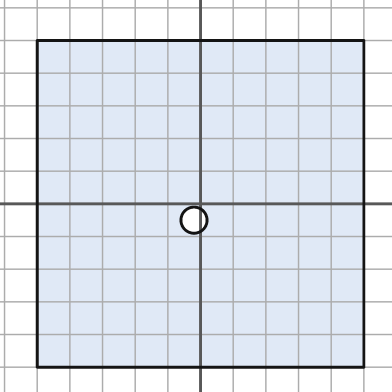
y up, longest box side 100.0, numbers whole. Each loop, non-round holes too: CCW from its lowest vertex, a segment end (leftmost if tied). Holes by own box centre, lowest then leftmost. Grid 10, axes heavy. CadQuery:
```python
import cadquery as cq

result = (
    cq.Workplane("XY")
    .moveTo(-50.0, -50.0)
    .lineTo(50.0, -50.0)
    .lineTo(50.0, 50.0)
    .lineTo(-50.0, 50.0)
    .close()
    .moveTo(-2.0, -5.0)
    .circle(4.0)
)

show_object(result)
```